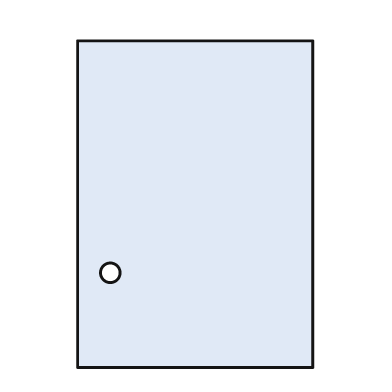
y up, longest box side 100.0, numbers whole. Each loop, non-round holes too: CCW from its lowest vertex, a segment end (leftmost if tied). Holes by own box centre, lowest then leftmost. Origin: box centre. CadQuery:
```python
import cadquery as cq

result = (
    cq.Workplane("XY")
    .moveTo(-36.0, -50.0)
    .lineTo(36.0, -50.0)
    .lineTo(36.0, 50.0)
    .lineTo(-36.0, 50.0)
    .close()
    .moveTo(-26.0, -21.0)
    .circle(3.0)
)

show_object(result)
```